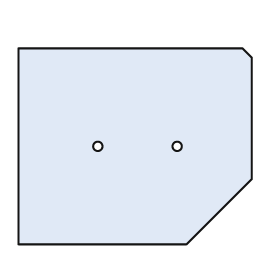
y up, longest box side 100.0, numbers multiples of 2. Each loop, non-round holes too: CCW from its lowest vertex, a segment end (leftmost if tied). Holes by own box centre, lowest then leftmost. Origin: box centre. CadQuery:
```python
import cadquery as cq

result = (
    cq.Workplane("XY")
    .moveTo(-50.0, -42.0)
    .lineTo(22.0, -42.0)
    .lineTo(50.0, -14.0)
    .lineTo(50.0, 38.0)
    .lineTo(46.0, 42.0)
    .lineTo(-50.0, 42.0)
    .close()
    .moveTo(-16.0, 0.0)
    .circle(2.0)
    .moveTo(18.0, 0.0)
    .circle(2.0)
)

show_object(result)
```